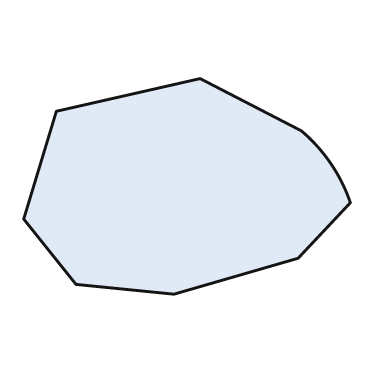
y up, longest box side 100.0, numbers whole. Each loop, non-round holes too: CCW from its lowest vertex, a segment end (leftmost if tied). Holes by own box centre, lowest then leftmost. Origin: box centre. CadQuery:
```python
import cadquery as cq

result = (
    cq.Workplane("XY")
    .moveTo(-4.0, -33.0)
    .lineTo(34.0, -22.0)
    .lineTo(50.0, -5.0)
    .threePointArc((44.0, 7.0), (35.0, 17.0))
    .lineTo(4.0, 33.0)
    .lineTo(-40.0, 23.0)
    .lineTo(-50.0, -10.0)
    .lineTo(-34.0, -30.0)
    .close()
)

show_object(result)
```